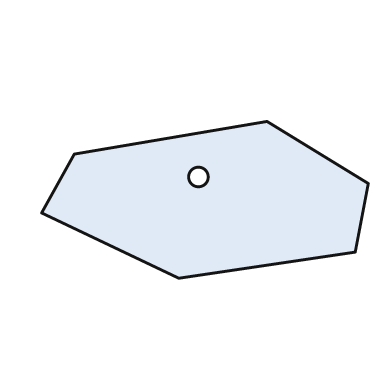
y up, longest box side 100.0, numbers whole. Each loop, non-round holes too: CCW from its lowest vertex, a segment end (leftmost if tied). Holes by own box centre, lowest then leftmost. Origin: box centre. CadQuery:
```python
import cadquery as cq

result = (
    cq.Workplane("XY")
    .moveTo(-8.0, -24.0)
    .lineTo(46.0, -16.0)
    .lineTo(50.0, 5.0)
    .lineTo(19.0, 24.0)
    .lineTo(-40.0, 14.0)
    .lineTo(-50.0, -4.0)
    .close()
    .moveTo(-2.0, 7.0)
    .circle(3.0)
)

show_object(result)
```